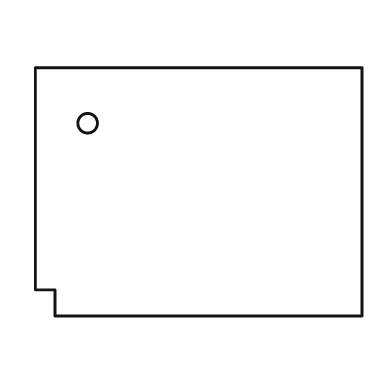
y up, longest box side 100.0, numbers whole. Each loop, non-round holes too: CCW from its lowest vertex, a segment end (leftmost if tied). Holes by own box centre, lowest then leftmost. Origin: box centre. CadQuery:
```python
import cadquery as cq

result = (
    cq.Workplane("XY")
    .moveTo(-44.0, -38.0)
    .lineTo(50.0, -38.0)
    .lineTo(50.0, 38.0)
    .lineTo(-50.0, 38.0)
    .lineTo(-50.0, -30.0)
    .lineTo(-44.0, -30.0)
    .close()
    .moveTo(-34.0, 21.0)
    .circle(3.0)
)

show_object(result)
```